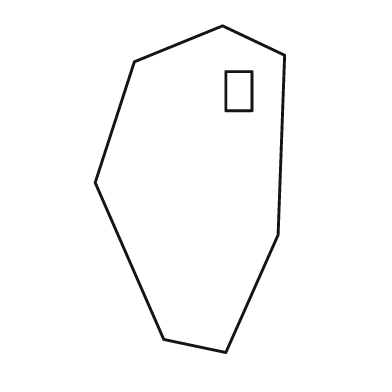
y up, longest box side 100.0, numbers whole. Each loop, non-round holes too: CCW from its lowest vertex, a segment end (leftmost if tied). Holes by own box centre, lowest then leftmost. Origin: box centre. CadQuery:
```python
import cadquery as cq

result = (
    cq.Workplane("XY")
    .moveTo(11.0, -50.0)
    .lineTo(27.0, -14.0)
    .lineTo(29.0, 41.0)
    .lineTo(10.0, 50.0)
    .lineTo(-17.0, 39.0)
    .lineTo(-29.0, 2.0)
    .lineTo(-8.0, -46.0)
    .close()
    .moveTo(11.0, 24.0)
    .lineTo(19.0, 24.0)
    .lineTo(19.0, 36.0)
    .lineTo(11.0, 36.0)
    .close()
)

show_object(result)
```